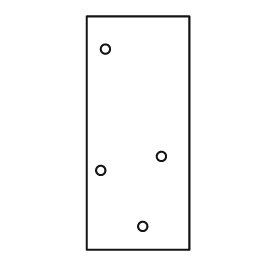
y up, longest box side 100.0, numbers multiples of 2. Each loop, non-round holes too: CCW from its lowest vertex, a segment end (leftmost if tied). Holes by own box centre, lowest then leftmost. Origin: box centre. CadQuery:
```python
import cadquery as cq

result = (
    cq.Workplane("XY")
    .moveTo(-22.0, -50.0)
    .lineTo(22.0, -50.0)
    .lineTo(22.0, 50.0)
    .lineTo(-22.0, 50.0)
    .close()
    .moveTo(2.0, -40.0)
    .circle(2.0)
    .moveTo(-16.0, -16.0)
    .circle(2.0)
    .moveTo(10.0, -10.0)
    .circle(2.0)
    .moveTo(-14.0, 36.0)
    .circle(2.0)
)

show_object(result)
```